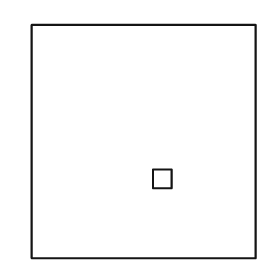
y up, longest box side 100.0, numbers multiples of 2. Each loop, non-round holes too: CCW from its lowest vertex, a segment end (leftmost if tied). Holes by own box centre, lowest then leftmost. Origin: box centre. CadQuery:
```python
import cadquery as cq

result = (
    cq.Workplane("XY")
    .moveTo(-48.0, -50.0)
    .lineTo(48.0, -50.0)
    .lineTo(48.0, 50.0)
    .lineTo(-48.0, 50.0)
    .close()
    .moveTo(4.0, -20.0)
    .lineTo(12.0, -20.0)
    .lineTo(12.0, -12.0)
    .lineTo(4.0, -12.0)
    .close()
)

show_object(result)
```